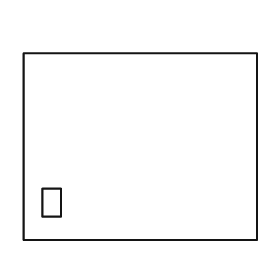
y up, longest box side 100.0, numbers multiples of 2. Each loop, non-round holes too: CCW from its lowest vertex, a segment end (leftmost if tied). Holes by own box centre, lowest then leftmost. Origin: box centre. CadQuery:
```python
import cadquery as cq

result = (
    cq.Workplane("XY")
    .moveTo(-50.0, -40.0)
    .lineTo(50.0, -40.0)
    .lineTo(50.0, 40.0)
    .lineTo(-50.0, 40.0)
    .close()
    .moveTo(-42.0, -30.0)
    .lineTo(-34.0, -30.0)
    .lineTo(-34.0, -18.0)
    .lineTo(-42.0, -18.0)
    .close()
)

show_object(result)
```